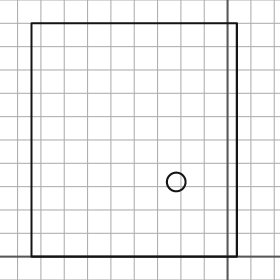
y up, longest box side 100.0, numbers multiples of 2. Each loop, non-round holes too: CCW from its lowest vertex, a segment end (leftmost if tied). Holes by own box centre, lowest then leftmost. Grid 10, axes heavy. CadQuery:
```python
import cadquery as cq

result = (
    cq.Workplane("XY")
    .moveTo(-84.0, 0.0)
    .lineTo(4.0, 0.0)
    .lineTo(4.0, 100.0)
    .lineTo(-84.0, 100.0)
    .close()
    .moveTo(-22.0, 32.0)
    .circle(4.0)
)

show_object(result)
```